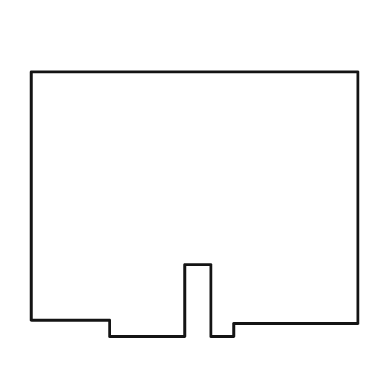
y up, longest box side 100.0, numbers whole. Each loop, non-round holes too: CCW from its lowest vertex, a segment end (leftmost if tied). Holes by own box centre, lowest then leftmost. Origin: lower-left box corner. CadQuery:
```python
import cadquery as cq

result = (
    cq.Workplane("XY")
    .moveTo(24.0, 0.0)
    .lineTo(47.0, 0.0)
    .lineTo(47.0, 22.0)
    .lineTo(55.0, 22.0)
    .lineTo(55.0, 0.0)
    .lineTo(62.0, 0.0)
    .lineTo(62.0, 4.0)
    .lineTo(100.0, 4.0)
    .lineTo(100.0, 81.0)
    .lineTo(0.0, 81.0)
    .lineTo(0.0, 5.0)
    .lineTo(24.0, 5.0)
    .close()
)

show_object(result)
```